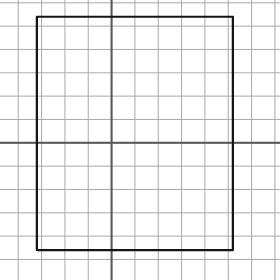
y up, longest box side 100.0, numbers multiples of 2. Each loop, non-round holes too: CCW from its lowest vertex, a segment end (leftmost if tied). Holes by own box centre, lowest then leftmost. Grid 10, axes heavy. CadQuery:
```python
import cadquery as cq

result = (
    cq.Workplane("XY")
    .moveTo(-32.0, -46.0)
    .lineTo(52.0, -46.0)
    .lineTo(52.0, 54.0)
    .lineTo(-32.0, 54.0)
    .close()
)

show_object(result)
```